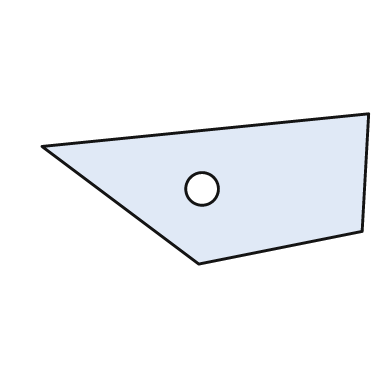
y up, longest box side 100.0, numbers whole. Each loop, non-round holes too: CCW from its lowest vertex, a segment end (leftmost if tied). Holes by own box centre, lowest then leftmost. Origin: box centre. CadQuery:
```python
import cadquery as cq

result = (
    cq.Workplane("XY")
    .moveTo(-2.0, -23.0)
    .lineTo(48.0, -13.0)
    .lineTo(50.0, 23.0)
    .lineTo(-50.0, 13.0)
    .close()
    .moveTo(-1.0, 0.0)
    .circle(5.0)
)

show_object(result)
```